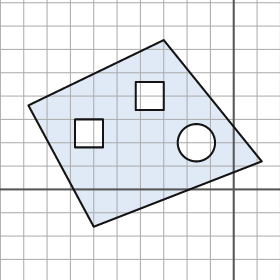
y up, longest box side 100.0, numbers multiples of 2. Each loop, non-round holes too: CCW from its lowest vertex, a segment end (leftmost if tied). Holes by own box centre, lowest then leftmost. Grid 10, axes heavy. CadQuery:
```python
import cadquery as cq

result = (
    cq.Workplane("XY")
    .moveTo(-60.0, -16.0)
    .lineTo(12.0, 12.0)
    .lineTo(-30.0, 64.0)
    .lineTo(-88.0, 36.0)
    .close()
    .moveTo(-16.0, 20.0)
    .circle(8.0)
    .moveTo(-68.0, 18.0)
    .lineTo(-56.0, 18.0)
    .lineTo(-56.0, 30.0)
    .lineTo(-68.0, 30.0)
    .close()
    .moveTo(-42.0, 34.0)
    .lineTo(-30.0, 34.0)
    .lineTo(-30.0, 46.0)
    .lineTo(-42.0, 46.0)
    .close()
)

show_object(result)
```